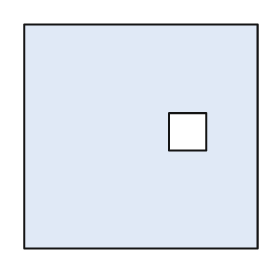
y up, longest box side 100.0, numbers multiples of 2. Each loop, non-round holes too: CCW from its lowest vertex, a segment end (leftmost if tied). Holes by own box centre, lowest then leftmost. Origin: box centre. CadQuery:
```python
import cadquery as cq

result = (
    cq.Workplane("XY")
    .moveTo(-50.0, -48.0)
    .lineTo(50.0, -48.0)
    .lineTo(50.0, 48.0)
    .lineTo(-50.0, 48.0)
    .close()
    .moveTo(12.0, -6.0)
    .lineTo(28.0, -6.0)
    .lineTo(28.0, 10.0)
    .lineTo(12.0, 10.0)
    .close()
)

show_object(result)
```